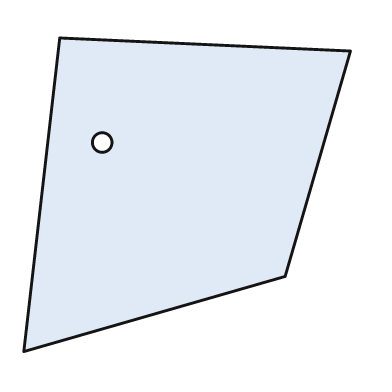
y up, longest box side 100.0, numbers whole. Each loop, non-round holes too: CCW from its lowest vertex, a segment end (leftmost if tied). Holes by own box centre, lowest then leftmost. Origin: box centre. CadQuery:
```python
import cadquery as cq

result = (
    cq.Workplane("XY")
    .moveTo(-50.0, -48.0)
    .lineTo(30.0, -25.0)
    .lineTo(50.0, 44.0)
    .lineTo(-39.0, 48.0)
    .close()
    .moveTo(-26.0, 16.0)
    .circle(3.0)
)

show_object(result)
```